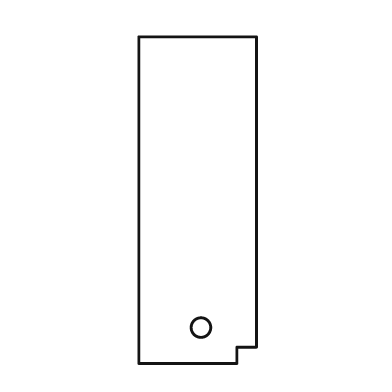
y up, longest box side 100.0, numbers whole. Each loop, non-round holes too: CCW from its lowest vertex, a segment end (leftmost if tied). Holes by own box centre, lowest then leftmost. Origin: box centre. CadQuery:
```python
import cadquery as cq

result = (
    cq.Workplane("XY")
    .moveTo(-18.0, -50.0)
    .lineTo(12.0, -50.0)
    .lineTo(12.0, -45.0)
    .lineTo(18.0, -45.0)
    .lineTo(18.0, 50.0)
    .lineTo(-18.0, 50.0)
    .close()
    .moveTo(1.0, -39.0)
    .circle(3.0)
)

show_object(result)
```